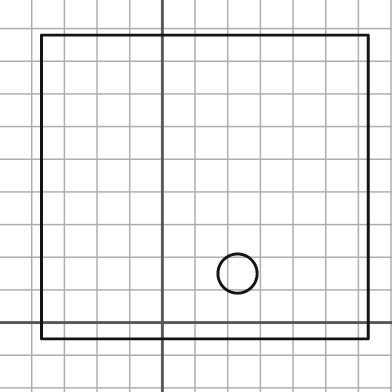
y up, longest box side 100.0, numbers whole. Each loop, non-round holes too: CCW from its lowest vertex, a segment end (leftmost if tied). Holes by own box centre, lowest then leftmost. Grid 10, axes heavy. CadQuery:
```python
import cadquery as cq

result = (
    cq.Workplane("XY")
    .moveTo(-37.0, -5.0)
    .lineTo(63.0, -5.0)
    .lineTo(63.0, 88.0)
    .lineTo(-37.0, 88.0)
    .close()
    .moveTo(23.0, 15.0)
    .circle(6.0)
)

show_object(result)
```